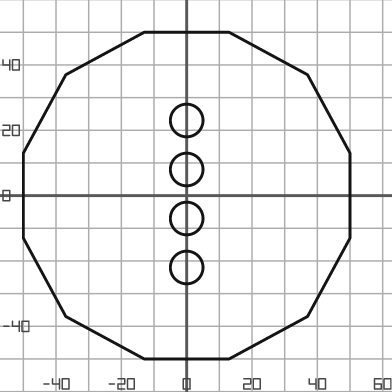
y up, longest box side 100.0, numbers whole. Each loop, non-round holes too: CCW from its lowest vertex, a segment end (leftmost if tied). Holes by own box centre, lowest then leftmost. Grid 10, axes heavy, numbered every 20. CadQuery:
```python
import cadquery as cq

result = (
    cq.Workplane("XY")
    .moveTo(-13.0, -50.0)
    .lineTo(13.0, -50.0)
    .lineTo(37.0, -37.0)
    .lineTo(50.0, -13.0)
    .lineTo(50.0, 13.0)
    .lineTo(37.0, 37.0)
    .lineTo(13.0, 50.0)
    .lineTo(-13.0, 50.0)
    .lineTo(-37.0, 37.0)
    .lineTo(-50.0, 13.0)
    .lineTo(-50.0, -13.0)
    .lineTo(-37.0, -37.0)
    .close()
    .moveTo(0.0, -22.0)
    .circle(5.0)
    .moveTo(0.0, -7.0)
    .circle(5.0)
    .moveTo(0.0, 8.0)
    .circle(5.0)
    .moveTo(0.0, 23.0)
    .circle(5.0)
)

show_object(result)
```